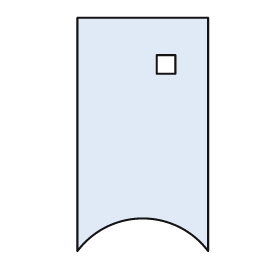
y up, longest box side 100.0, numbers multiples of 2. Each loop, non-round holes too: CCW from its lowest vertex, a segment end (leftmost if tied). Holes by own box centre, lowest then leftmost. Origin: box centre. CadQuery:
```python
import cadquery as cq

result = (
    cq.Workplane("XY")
    .moveTo(-28.0, -50.0)
    .threePointArc((0.0, -36.0), (28.0, -50.0))
    .lineTo(28.0, 50.0)
    .lineTo(-28.0, 50.0)
    .close()
    .moveTo(6.0, 26.0)
    .lineTo(14.0, 26.0)
    .lineTo(14.0, 34.0)
    .lineTo(6.0, 34.0)
    .close()
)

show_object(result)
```